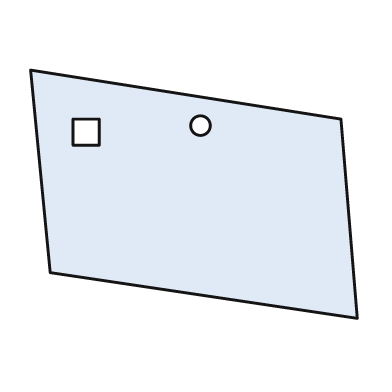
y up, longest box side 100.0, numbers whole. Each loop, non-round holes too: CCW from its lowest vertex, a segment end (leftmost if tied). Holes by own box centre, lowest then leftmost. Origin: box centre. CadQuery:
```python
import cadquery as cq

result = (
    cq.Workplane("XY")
    .moveTo(50.0, -38.0)
    .lineTo(45.0, 23.0)
    .lineTo(-50.0, 38.0)
    .lineTo(-44.0, -24.0)
    .close()
    .moveTo(-37.0, 15.0)
    .lineTo(-29.0, 15.0)
    .lineTo(-29.0, 23.0)
    .lineTo(-37.0, 23.0)
    .close()
    .moveTo(2.0, 21.0)
    .circle(3.0)
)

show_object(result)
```